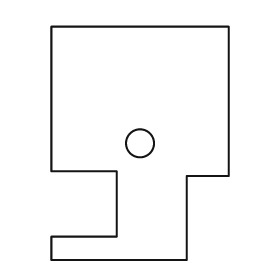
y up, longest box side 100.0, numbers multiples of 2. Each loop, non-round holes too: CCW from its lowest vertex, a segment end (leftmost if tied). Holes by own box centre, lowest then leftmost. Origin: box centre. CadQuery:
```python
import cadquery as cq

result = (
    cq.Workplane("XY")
    .moveTo(-38.0, -50.0)
    .lineTo(20.0, -50.0)
    .lineTo(20.0, -14.0)
    .lineTo(38.0, -14.0)
    .lineTo(38.0, 50.0)
    .lineTo(-38.0, 50.0)
    .lineTo(-38.0, -12.0)
    .lineTo(-10.0, -12.0)
    .lineTo(-10.0, -40.0)
    .lineTo(-38.0, -40.0)
    .close()
    .moveTo(0.0, 0.0)
    .circle(6.0)
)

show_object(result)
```